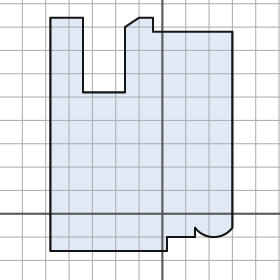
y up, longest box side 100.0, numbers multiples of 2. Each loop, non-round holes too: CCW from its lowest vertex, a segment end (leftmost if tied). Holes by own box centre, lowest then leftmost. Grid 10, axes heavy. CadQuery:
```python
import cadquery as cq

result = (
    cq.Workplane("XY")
    .moveTo(-48.0, -16.0)
    .lineTo(2.0, -16.0)
    .lineTo(2.0, -10.0)
    .lineTo(14.0, -10.0)
    .lineTo(14.0, -6.0)
    .threePointArc((22.0, -10.0), (30.0, -6.0))
    .lineTo(30.0, 78.0)
    .lineTo(-4.0, 78.0)
    .lineTo(-4.0, 84.0)
    .lineTo(-10.0, 84.0)
    .lineTo(-16.0, 80.0)
    .lineTo(-16.0, 52.0)
    .lineTo(-34.0, 52.0)
    .lineTo(-34.0, 84.0)
    .lineTo(-48.0, 84.0)
    .close()
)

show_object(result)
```